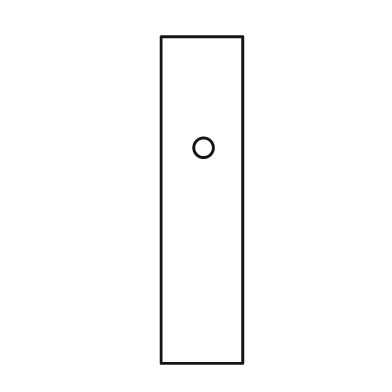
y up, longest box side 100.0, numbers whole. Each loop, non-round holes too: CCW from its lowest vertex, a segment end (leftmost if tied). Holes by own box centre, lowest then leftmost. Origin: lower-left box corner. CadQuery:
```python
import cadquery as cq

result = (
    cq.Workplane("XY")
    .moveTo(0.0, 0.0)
    .lineTo(25.0, 0.0)
    .lineTo(25.0, 100.0)
    .lineTo(0.0, 100.0)
    .close()
    .moveTo(13.0, 66.0)
    .circle(3.0)
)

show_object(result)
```